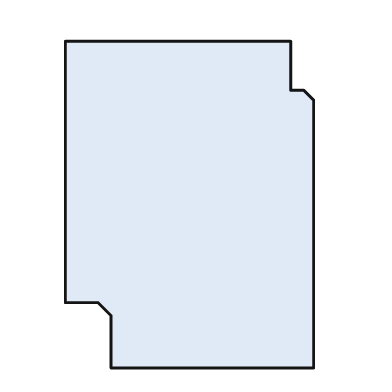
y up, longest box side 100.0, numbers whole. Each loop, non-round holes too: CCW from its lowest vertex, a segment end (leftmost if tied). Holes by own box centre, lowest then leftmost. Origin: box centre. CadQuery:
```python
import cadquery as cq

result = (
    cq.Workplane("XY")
    .moveTo(-24.0, -50.0)
    .lineTo(38.0, -50.0)
    .lineTo(38.0, 32.0)
    .lineTo(35.0, 35.0)
    .lineTo(31.0, 35.0)
    .lineTo(31.0, 50.0)
    .lineTo(-38.0, 50.0)
    .lineTo(-38.0, -30.0)
    .lineTo(-28.0, -30.0)
    .lineTo(-24.0, -34.0)
    .close()
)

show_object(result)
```